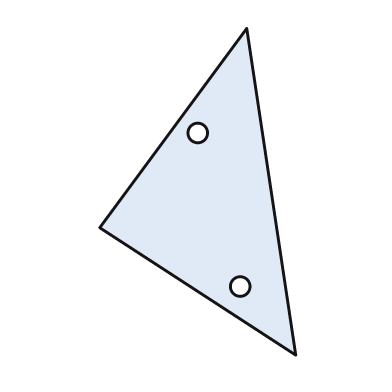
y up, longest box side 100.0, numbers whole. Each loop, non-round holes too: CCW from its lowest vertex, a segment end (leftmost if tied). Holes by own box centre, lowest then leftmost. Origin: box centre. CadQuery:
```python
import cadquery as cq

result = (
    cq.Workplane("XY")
    .moveTo(30.0, -50.0)
    .lineTo(15.0, 50.0)
    .lineTo(-30.0, -11.0)
    .close()
    .moveTo(13.0, -29.0)
    .circle(3.0)
    .moveTo(0.0, 18.0)
    .circle(3.0)
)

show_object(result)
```